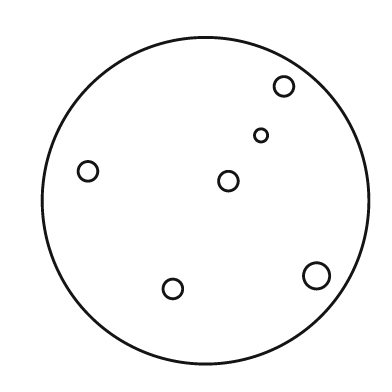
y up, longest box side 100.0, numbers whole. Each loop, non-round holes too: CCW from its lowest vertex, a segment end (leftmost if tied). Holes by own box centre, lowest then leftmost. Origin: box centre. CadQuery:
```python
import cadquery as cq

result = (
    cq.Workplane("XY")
    .moveTo(0.0, 0.0)
    .circle(50.0)
    .moveTo(-10.0, -27.0)
    .circle(3.0)
    .moveTo(34.0, -23.0)
    .circle(4.0)
    .moveTo(7.0, 6.0)
    .circle(3.0)
    .moveTo(-36.0, 9.0)
    .circle(3.0)
    .moveTo(17.0, 20.0)
    .circle(2.0)
    .moveTo(24.0, 35.0)
    .circle(3.0)
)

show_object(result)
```